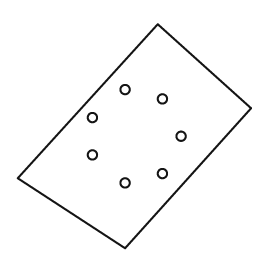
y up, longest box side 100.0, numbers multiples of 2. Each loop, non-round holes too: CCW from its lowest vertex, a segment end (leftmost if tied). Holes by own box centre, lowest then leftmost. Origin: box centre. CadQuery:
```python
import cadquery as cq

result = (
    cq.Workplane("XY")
    .moveTo(-4.0, -48.0)
    .lineTo(50.0, 12.0)
    .lineTo(10.0, 48.0)
    .lineTo(-50.0, -18.0)
    .close()
    .moveTo(-4.0, -20.0)
    .circle(2.0)
    .moveTo(12.0, -16.0)
    .circle(2.0)
    .moveTo(-18.0, -8.0)
    .circle(2.0)
    .moveTo(20.0, 0.0)
    .circle(2.0)
    .moveTo(-18.0, 8.0)
    .circle(2.0)
    .moveTo(12.0, 16.0)
    .circle(2.0)
    .moveTo(-4.0, 20.0)
    .circle(2.0)
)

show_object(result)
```